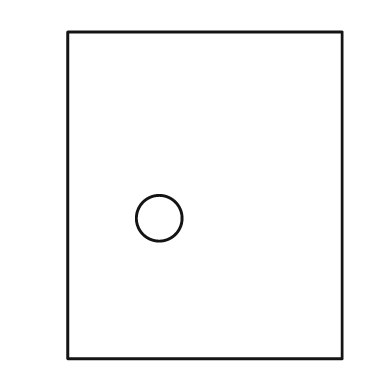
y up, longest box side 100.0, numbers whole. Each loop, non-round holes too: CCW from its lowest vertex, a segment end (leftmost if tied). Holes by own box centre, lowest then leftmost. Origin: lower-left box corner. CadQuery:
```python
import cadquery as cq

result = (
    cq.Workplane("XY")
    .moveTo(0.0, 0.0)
    .lineTo(84.0, 0.0)
    .lineTo(84.0, 100.0)
    .lineTo(0.0, 100.0)
    .close()
    .moveTo(28.0, 43.0)
    .circle(7.0)
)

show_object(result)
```